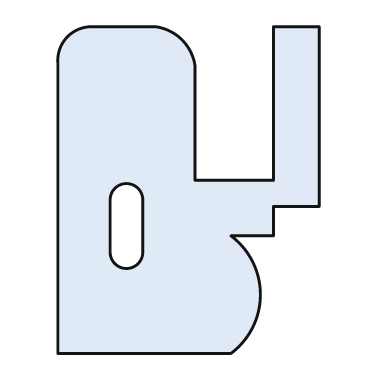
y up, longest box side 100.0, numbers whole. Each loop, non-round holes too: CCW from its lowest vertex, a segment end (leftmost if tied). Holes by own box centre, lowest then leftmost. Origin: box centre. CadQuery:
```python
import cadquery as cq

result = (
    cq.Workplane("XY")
    .moveTo(-40.0, -50.0)
    .lineTo(13.0, -50.0)
    .threePointArc((22.0, -32.0), (13.0, -14.0))
    .lineTo(26.0, -14.0)
    .lineTo(26.0, -5.0)
    .lineTo(40.0, -5.0)
    .lineTo(40.0, 50.0)
    .lineTo(26.0, 50.0)
    .lineTo(26.0, 3.0)
    .lineTo(2.0, 3.0)
    .lineTo(2.0, 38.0)
    .threePointArc((-2.0, 46.0), (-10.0, 50.0))
    .lineTo(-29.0, 50.0)
    .threePointArc((-37.0, 47.0), (-40.0, 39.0))
    .close()
    .moveTo(-24.0, -19.0)
    .threePointArc((-19.0, -24.0), (-14.0, -19.0))
    .lineTo(-14.0, -3.0)
    .threePointArc((-19.0, 2.0), (-24.0, -3.0))
    .close()
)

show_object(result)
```